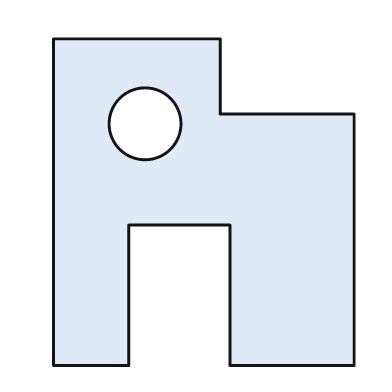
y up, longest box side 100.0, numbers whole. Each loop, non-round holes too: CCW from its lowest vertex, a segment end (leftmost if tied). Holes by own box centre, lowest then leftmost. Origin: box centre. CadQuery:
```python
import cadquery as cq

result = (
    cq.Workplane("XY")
    .moveTo(-46.0, -50.0)
    .lineTo(-23.0, -50.0)
    .lineTo(-23.0, -7.0)
    .lineTo(8.0, -7.0)
    .lineTo(8.0, -50.0)
    .lineTo(46.0, -50.0)
    .lineTo(46.0, 27.0)
    .lineTo(5.0, 27.0)
    .lineTo(5.0, 50.0)
    .lineTo(-46.0, 50.0)
    .close()
    .moveTo(-18.0, 24.0)
    .circle(11.0)
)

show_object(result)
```